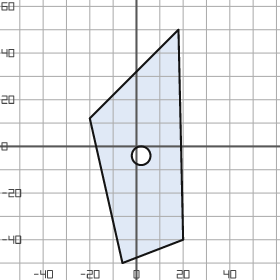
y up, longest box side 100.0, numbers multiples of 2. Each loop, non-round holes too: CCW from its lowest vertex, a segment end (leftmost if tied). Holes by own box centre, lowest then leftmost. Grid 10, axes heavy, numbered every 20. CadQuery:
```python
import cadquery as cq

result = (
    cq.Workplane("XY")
    .moveTo(-6.0, -50.0)
    .lineTo(20.0, -40.0)
    .lineTo(18.0, 50.0)
    .lineTo(-20.0, 12.0)
    .close()
    .moveTo(2.0, -4.0)
    .circle(4.0)
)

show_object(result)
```